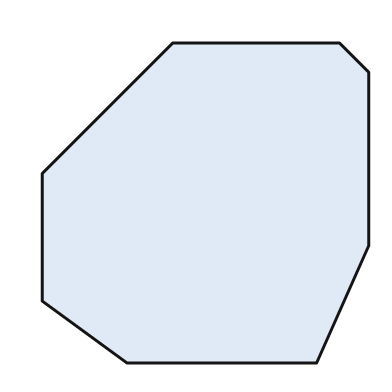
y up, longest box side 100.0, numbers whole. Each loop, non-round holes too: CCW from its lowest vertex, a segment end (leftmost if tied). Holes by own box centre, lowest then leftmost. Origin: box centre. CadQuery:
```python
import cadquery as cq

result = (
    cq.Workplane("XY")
    .moveTo(-24.0, -49.0)
    .lineTo(34.0, -49.0)
    .lineTo(50.0, -13.0)
    .lineTo(50.0, 40.0)
    .lineTo(41.0, 49.0)
    .lineTo(-10.0, 49.0)
    .lineTo(-50.0, 9.0)
    .lineTo(-50.0, -30.0)
    .close()
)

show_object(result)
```